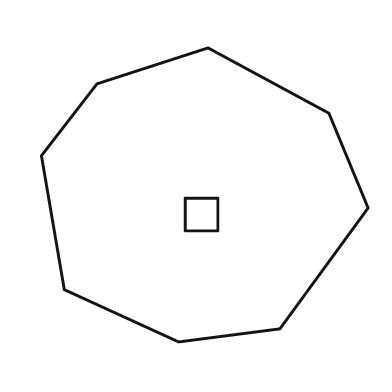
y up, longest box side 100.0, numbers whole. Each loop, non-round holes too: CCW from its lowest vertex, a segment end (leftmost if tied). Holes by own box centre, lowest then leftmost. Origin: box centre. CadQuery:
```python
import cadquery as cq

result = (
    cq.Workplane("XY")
    .moveTo(-8.0, -45.0)
    .lineTo(23.0, -41.0)
    .lineTo(50.0, -4.0)
    .lineTo(38.0, 25.0)
    .lineTo(1.0, 45.0)
    .lineTo(-33.0, 34.0)
    .lineTo(-50.0, 12.0)
    .lineTo(-43.0, -29.0)
    .close()
    .moveTo(-6.0, -11.0)
    .lineTo(4.0, -11.0)
    .lineTo(4.0, -1.0)
    .lineTo(-6.0, -1.0)
    .close()
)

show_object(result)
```